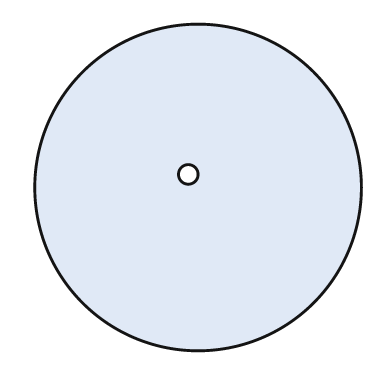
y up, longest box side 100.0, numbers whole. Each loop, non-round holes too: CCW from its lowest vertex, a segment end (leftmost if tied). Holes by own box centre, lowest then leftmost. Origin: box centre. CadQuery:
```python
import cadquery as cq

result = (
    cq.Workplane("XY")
    .moveTo(0.0, 0.0)
    .circle(50.0)
    .moveTo(-3.0, 4.0)
    .circle(3.0)
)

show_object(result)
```